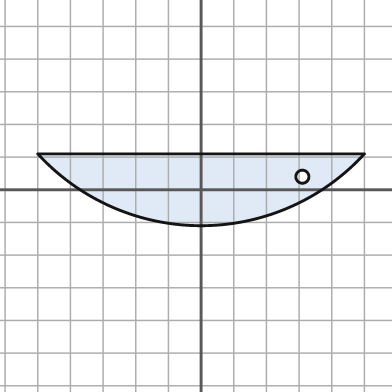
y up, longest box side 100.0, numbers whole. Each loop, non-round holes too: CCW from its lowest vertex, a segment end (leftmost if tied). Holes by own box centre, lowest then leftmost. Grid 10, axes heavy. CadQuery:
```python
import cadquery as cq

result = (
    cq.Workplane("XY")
    .moveTo(-50.0, 11.0)
    .threePointArc((0.0, -11.0), (50.0, 11.0))
    .close()
    .moveTo(31.0, 4.0)
    .circle(2.0)
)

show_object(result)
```